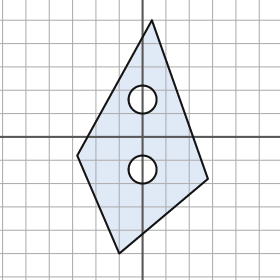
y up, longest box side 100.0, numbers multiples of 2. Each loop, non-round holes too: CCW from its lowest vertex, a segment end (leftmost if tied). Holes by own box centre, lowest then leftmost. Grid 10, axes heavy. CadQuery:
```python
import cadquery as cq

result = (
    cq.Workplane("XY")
    .moveTo(-10.0, -50.0)
    .lineTo(28.0, -18.0)
    .lineTo(4.0, 50.0)
    .lineTo(-28.0, -8.0)
    .close()
    .moveTo(0.0, -14.0)
    .circle(6.0)
    .moveTo(0.0, 16.0)
    .circle(6.0)
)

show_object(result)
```